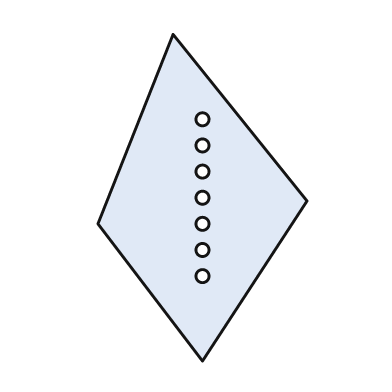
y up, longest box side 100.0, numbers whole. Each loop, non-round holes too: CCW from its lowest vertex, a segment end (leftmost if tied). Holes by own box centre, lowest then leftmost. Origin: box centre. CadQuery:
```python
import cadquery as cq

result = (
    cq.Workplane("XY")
    .moveTo(0.0, -50.0)
    .lineTo(32.0, -1.0)
    .lineTo(-9.0, 50.0)
    .lineTo(-32.0, -8.0)
    .close()
    .moveTo(0.0, -24.0)
    .circle(2.0)
    .moveTo(0.0, -16.0)
    .circle(2.0)
    .moveTo(0.0, -8.0)
    .circle(2.0)
    .moveTo(0.0, 0.0)
    .circle(2.0)
    .moveTo(0.0, 8.0)
    .circle(2.0)
    .moveTo(0.0, 16.0)
    .circle(2.0)
    .moveTo(0.0, 24.0)
    .circle(2.0)
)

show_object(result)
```